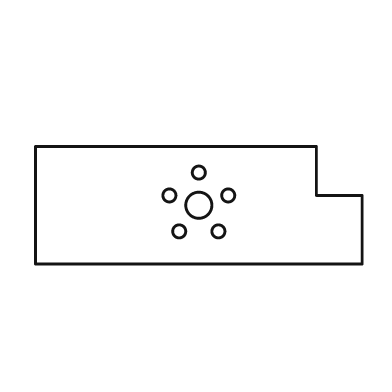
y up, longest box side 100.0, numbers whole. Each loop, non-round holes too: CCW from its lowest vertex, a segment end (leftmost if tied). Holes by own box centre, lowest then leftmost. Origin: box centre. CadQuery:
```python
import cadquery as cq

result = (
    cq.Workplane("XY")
    .moveTo(-50.0, -18.0)
    .lineTo(50.0, -18.0)
    .lineTo(50.0, 3.0)
    .lineTo(36.0, 3.0)
    .lineTo(36.0, 18.0)
    .lineTo(-50.0, 18.0)
    .close()
    .moveTo(-6.0, -8.0)
    .circle(2.0)
    .moveTo(6.0, -8.0)
    .circle(2.0)
    .moveTo(0.0, 0.0)
    .circle(4.0)
    .moveTo(-9.0, 3.0)
    .circle(2.0)
    .moveTo(9.0, 3.0)
    .circle(2.0)
    .moveTo(0.0, 10.0)
    .circle(2.0)
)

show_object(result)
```